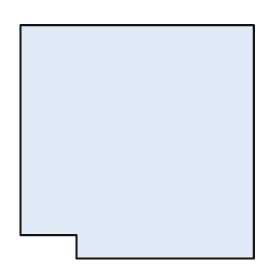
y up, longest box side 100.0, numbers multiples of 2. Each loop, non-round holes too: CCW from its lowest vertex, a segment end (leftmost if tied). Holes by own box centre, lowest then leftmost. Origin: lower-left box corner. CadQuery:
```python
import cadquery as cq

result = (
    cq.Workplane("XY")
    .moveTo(24.0, 0.0)
    .lineTo(100.0, 0.0)
    .lineTo(100.0, 100.0)
    .lineTo(0.0, 100.0)
    .lineTo(0.0, 10.0)
    .lineTo(24.0, 10.0)
    .close()
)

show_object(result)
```